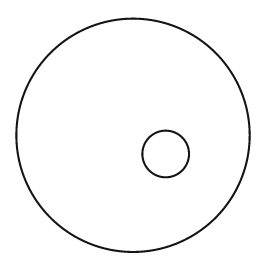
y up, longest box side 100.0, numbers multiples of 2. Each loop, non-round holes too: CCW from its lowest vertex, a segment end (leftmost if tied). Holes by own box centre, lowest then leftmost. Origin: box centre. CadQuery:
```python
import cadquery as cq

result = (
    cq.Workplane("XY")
    .moveTo(0.0, 0.0)
    .circle(50.0)
    .moveTo(14.0, -8.0)
    .circle(10.0)
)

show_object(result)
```